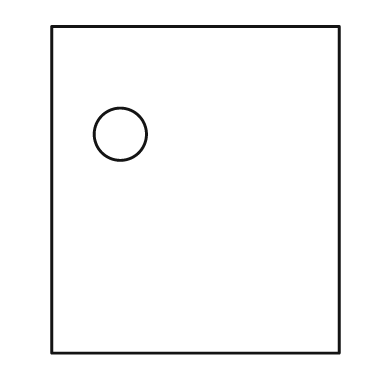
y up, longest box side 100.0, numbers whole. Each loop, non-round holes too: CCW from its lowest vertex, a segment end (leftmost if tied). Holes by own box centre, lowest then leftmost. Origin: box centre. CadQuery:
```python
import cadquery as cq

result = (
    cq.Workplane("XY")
    .moveTo(-44.0, -50.0)
    .lineTo(44.0, -50.0)
    .lineTo(44.0, 50.0)
    .lineTo(-44.0, 50.0)
    .close()
    .moveTo(-23.0, 17.0)
    .circle(8.0)
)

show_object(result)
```